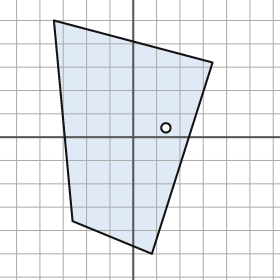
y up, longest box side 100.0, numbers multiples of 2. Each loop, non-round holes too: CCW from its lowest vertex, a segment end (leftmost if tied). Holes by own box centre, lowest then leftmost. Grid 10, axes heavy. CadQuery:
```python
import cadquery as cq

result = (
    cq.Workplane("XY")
    .moveTo(8.0, -50.0)
    .lineTo(34.0, 32.0)
    .lineTo(-34.0, 50.0)
    .lineTo(-26.0, -36.0)
    .close()
    .moveTo(14.0, 4.0)
    .circle(2.0)
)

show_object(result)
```